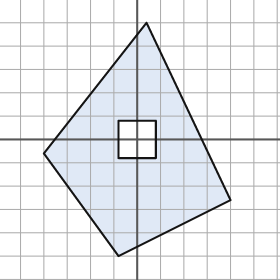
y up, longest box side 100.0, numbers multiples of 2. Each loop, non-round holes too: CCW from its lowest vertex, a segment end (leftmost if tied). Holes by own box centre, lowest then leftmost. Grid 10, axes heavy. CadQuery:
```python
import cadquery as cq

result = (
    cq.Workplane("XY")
    .moveTo(-8.0, -50.0)
    .lineTo(40.0, -26.0)
    .lineTo(4.0, 50.0)
    .lineTo(-40.0, -6.0)
    .close()
    .moveTo(-8.0, -8.0)
    .lineTo(8.0, -8.0)
    .lineTo(8.0, 8.0)
    .lineTo(-8.0, 8.0)
    .close()
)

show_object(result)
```